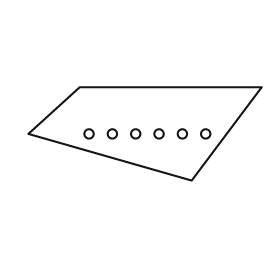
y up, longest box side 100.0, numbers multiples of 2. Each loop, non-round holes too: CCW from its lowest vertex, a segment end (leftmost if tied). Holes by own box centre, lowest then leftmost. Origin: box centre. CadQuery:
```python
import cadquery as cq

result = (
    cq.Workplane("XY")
    .moveTo(20.0, -20.0)
    .lineTo(50.0, 20.0)
    .lineTo(-28.0, 20.0)
    .lineTo(-50.0, 0.0)
    .close()
    .moveTo(-24.0, 0.0)
    .circle(2.0)
    .moveTo(-14.0, 0.0)
    .circle(2.0)
    .moveTo(-4.0, 0.0)
    .circle(2.0)
    .moveTo(6.0, 0.0)
    .circle(2.0)
    .moveTo(16.0, 0.0)
    .circle(2.0)
    .moveTo(26.0, 0.0)
    .circle(2.0)
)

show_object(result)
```